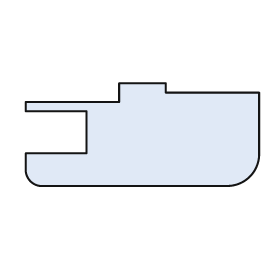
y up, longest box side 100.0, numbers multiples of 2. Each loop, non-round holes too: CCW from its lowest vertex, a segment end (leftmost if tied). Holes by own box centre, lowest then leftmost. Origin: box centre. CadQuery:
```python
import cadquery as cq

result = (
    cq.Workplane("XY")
    .moveTo(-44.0, -22.0)
    .lineTo(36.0, -22.0)
    .threePointArc((46.0, -18.0), (50.0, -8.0))
    .lineTo(50.0, 18.0)
    .lineTo(10.0, 18.0)
    .lineTo(10.0, 22.0)
    .lineTo(-10.0, 22.0)
    .lineTo(-10.0, 14.0)
    .lineTo(-50.0, 14.0)
    .lineTo(-50.0, 10.0)
    .lineTo(-24.0, 10.0)
    .lineTo(-24.0, -8.0)
    .lineTo(-50.0, -8.0)
    .lineTo(-50.0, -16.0)
    .threePointArc((-48.0, -20.0), (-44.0, -22.0))
    .close()
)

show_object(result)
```